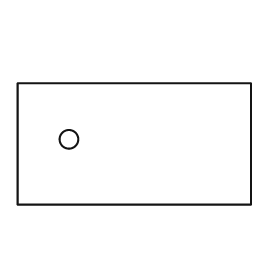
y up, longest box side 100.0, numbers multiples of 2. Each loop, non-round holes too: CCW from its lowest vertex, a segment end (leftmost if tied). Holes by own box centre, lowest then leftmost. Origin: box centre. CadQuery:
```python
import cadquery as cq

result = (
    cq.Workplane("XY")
    .moveTo(-50.0, -26.0)
    .lineTo(50.0, -26.0)
    .lineTo(50.0, 26.0)
    .lineTo(-50.0, 26.0)
    .close()
    .moveTo(-28.0, 2.0)
    .circle(4.0)
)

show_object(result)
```